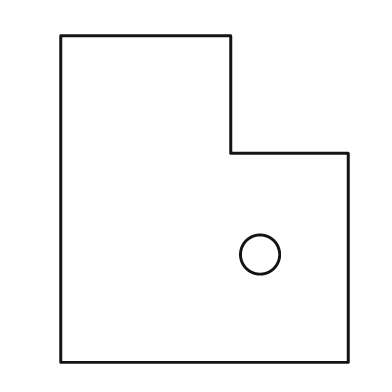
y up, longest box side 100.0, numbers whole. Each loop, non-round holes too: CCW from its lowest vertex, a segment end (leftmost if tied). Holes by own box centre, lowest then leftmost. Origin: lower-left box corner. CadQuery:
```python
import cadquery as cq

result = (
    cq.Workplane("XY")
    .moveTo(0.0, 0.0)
    .lineTo(88.0, 0.0)
    .lineTo(88.0, 64.0)
    .lineTo(52.0, 64.0)
    .lineTo(52.0, 100.0)
    .lineTo(0.0, 100.0)
    .close()
    .moveTo(61.0, 33.0)
    .circle(6.0)
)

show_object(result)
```